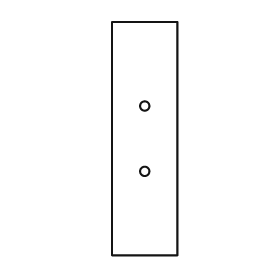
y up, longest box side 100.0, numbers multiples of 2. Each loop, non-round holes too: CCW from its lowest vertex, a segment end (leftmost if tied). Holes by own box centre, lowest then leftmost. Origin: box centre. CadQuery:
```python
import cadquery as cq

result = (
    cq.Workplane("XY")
    .moveTo(-14.0, -50.0)
    .lineTo(14.0, -50.0)
    .lineTo(14.0, 50.0)
    .lineTo(-14.0, 50.0)
    .close()
    .moveTo(0.0, -14.0)
    .circle(2.0)
    .moveTo(0.0, 14.0)
    .circle(2.0)
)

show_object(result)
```